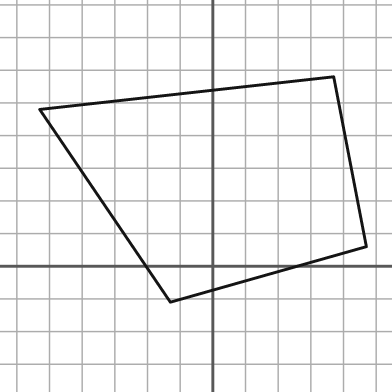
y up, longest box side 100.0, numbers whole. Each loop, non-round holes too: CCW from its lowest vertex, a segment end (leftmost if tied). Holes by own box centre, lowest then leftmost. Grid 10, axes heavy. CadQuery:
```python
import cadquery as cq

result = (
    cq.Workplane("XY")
    .moveTo(-13.0, -11.0)
    .lineTo(47.0, 6.0)
    .lineTo(37.0, 58.0)
    .lineTo(-53.0, 48.0)
    .close()
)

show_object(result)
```